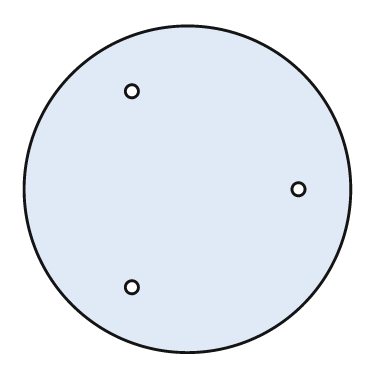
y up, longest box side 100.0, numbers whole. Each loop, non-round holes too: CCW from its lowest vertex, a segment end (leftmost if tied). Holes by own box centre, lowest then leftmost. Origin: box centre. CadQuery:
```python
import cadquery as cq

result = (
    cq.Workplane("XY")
    .moveTo(0.0, 0.0)
    .circle(50.0)
    .moveTo(-17.0, -30.0)
    .circle(2.0)
    .moveTo(34.0, 0.0)
    .circle(2.0)
    .moveTo(-17.0, 30.0)
    .circle(2.0)
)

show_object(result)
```